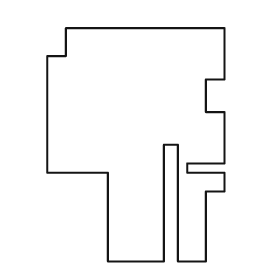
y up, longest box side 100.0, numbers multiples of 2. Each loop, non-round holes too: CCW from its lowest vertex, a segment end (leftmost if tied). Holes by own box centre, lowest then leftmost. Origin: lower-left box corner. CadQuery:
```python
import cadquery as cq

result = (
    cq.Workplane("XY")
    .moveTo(26.0, 0.0)
    .lineTo(50.0, 0.0)
    .lineTo(50.0, 50.0)
    .lineTo(56.0, 50.0)
    .lineTo(56.0, 0.0)
    .lineTo(68.0, 0.0)
    .lineTo(68.0, 30.0)
    .lineTo(76.0, 30.0)
    .lineTo(76.0, 38.0)
    .lineTo(60.0, 38.0)
    .lineTo(60.0, 42.0)
    .lineTo(76.0, 42.0)
    .lineTo(76.0, 64.0)
    .lineTo(68.0, 64.0)
    .lineTo(68.0, 78.0)
    .lineTo(76.0, 78.0)
    .lineTo(76.0, 100.0)
    .lineTo(8.0, 100.0)
    .lineTo(8.0, 88.0)
    .lineTo(0.0, 88.0)
    .lineTo(0.0, 38.0)
    .lineTo(26.0, 38.0)
    .close()
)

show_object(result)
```